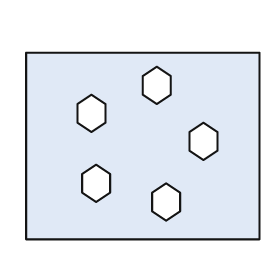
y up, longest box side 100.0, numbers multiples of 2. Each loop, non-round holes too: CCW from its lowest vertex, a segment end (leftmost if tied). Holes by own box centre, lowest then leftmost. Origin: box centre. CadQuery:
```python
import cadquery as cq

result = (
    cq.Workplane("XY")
    .moveTo(-50.0, -40.0)
    .lineTo(50.0, -40.0)
    .lineTo(50.0, 40.0)
    .lineTo(-50.0, 40.0)
    .close()
    .moveTo(10.0, -32.0)
    .lineTo(16.0, -28.0)
    .lineTo(16.0, -20.0)
    .lineTo(10.0, -16.0)
    .lineTo(4.0, -20.0)
    .lineTo(4.0, -28.0)
    .close()
    .moveTo(-20.0, -24.0)
    .lineTo(-14.0, -20.0)
    .lineTo(-14.0, -12.0)
    .lineTo(-20.0, -8.0)
    .lineTo(-26.0, -12.0)
    .lineTo(-26.0, -20.0)
    .close()
    .moveTo(26.0, -6.0)
    .lineTo(32.0, -2.0)
    .lineTo(32.0, 6.0)
    .lineTo(26.0, 10.0)
    .lineTo(20.0, 6.0)
    .lineTo(20.0, -2.0)
    .close()
    .moveTo(-22.0, 6.0)
    .lineTo(-16.0, 10.0)
    .lineTo(-16.0, 18.0)
    .lineTo(-22.0, 22.0)
    .lineTo(-28.0, 18.0)
    .lineTo(-28.0, 10.0)
    .close()
    .moveTo(6.0, 18.0)
    .lineTo(12.0, 22.0)
    .lineTo(12.0, 30.0)
    .lineTo(6.0, 34.0)
    .lineTo(0.0, 30.0)
    .lineTo(0.0, 22.0)
    .close()
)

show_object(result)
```